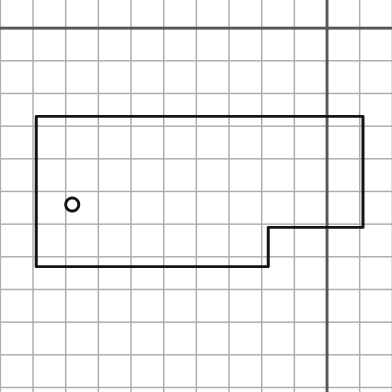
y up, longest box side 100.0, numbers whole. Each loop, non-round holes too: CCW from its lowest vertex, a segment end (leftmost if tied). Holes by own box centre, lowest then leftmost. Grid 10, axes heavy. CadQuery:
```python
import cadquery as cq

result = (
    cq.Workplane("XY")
    .moveTo(-89.0, -73.0)
    .lineTo(-18.0, -73.0)
    .lineTo(-18.0, -61.0)
    .lineTo(11.0, -61.0)
    .lineTo(11.0, -27.0)
    .lineTo(-89.0, -27.0)
    .close()
    .moveTo(-78.0, -54.0)
    .circle(2.0)
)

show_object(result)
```